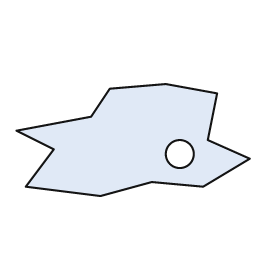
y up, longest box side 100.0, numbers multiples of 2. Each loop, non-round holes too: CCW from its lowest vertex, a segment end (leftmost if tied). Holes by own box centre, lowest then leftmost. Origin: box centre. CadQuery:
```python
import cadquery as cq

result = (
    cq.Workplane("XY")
    .moveTo(-14.0, -24.0)
    .lineTo(8.0, -18.0)
    .lineTo(30.0, -20.0)
    .lineTo(50.0, -8.0)
    .lineTo(32.0, 0.0)
    .lineTo(36.0, 20.0)
    .lineTo(14.0, 24.0)
    .lineTo(-10.0, 22.0)
    .lineTo(-18.0, 10.0)
    .lineTo(-50.0, 4.0)
    .lineTo(-34.0, -4.0)
    .lineTo(-46.0, -20.0)
    .close()
    .moveTo(20.0, -6.0)
    .circle(6.0)
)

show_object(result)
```